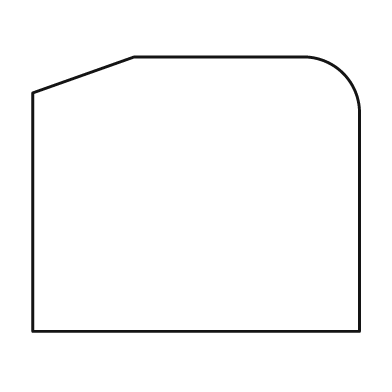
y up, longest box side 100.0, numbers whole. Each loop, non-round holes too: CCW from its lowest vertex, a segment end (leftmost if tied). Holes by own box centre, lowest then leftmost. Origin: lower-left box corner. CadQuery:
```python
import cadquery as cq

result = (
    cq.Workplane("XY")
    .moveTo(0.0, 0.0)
    .lineTo(100.0, 0.0)
    .lineTo(100.0, 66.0)
    .threePointArc((95.0, 79.0), (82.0, 84.0))
    .lineTo(31.0, 84.0)
    .lineTo(0.0, 73.0)
    .close()
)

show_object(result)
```